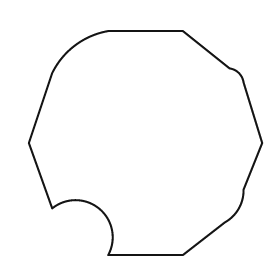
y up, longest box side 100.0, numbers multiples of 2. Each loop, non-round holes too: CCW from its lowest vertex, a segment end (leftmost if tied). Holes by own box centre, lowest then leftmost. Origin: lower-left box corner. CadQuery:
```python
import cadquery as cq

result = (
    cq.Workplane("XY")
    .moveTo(34.0, 0.0)
    .lineTo(66.0, 0.0)
    .lineTo(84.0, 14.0)
    .threePointArc((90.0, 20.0), (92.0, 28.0))
    .lineTo(100.0, 48.0)
    .lineTo(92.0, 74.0)
    .threePointArc((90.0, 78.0), (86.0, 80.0))
    .lineTo(66.0, 96.0)
    .lineTo(34.0, 96.0)
    .threePointArc((20.0, 90.0), (10.0, 78.0))
    .lineTo(0.0, 48.0)
    .lineTo(10.0, 20.0)
    .threePointArc((30.0, 20.0), (34.0, 0.0))
    .close()
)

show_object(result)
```